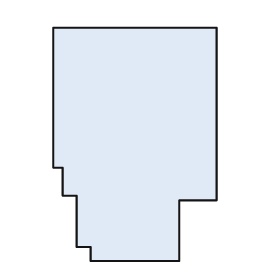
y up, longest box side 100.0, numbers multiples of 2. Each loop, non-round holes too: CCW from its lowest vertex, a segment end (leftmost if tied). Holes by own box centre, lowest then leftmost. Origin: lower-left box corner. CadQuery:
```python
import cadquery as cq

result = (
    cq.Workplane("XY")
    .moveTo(16.0, 0.0)
    .lineTo(54.0, 0.0)
    .lineTo(54.0, 26.0)
    .lineTo(70.0, 26.0)
    .lineTo(70.0, 100.0)
    .lineTo(0.0, 100.0)
    .lineTo(0.0, 40.0)
    .lineTo(4.0, 40.0)
    .lineTo(4.0, 28.0)
    .lineTo(10.0, 28.0)
    .lineTo(10.0, 6.0)
    .lineTo(16.0, 6.0)
    .close()
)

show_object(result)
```